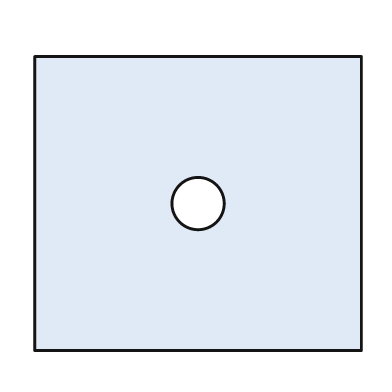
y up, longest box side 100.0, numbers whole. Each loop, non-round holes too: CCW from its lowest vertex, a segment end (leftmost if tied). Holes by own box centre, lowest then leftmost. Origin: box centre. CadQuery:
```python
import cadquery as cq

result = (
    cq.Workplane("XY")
    .moveTo(-50.0, -45.0)
    .lineTo(50.0, -45.0)
    .lineTo(50.0, 45.0)
    .lineTo(-50.0, 45.0)
    .close()
    .moveTo(0.0, 0.0)
    .circle(8.0)
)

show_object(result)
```